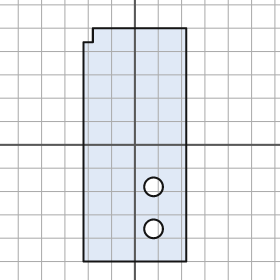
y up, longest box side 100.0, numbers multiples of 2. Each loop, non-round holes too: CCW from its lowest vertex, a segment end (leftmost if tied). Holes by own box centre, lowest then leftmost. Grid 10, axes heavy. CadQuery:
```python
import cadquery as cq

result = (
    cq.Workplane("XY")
    .moveTo(-22.0, -50.0)
    .lineTo(22.0, -50.0)
    .lineTo(22.0, 50.0)
    .lineTo(-18.0, 50.0)
    .lineTo(-18.0, 44.0)
    .lineTo(-22.0, 44.0)
    .close()
    .moveTo(8.0, -36.0)
    .circle(4.0)
    .moveTo(8.0, -18.0)
    .circle(4.0)
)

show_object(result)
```